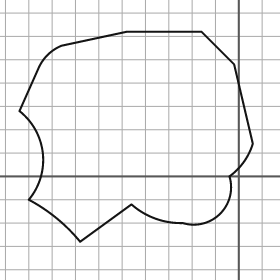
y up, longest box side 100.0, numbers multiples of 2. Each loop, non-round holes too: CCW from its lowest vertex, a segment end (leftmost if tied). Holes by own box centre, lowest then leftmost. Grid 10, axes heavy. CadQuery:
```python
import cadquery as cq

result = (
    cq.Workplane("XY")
    .moveTo(-68.0, -28.0)
    .lineTo(-46.0, -12.0)
    .threePointArc((-36.0, -18.0), (-24.0, -20.0))
    .threePointArc((-8.0, -16.0), (-4.0, 0.0))
    .threePointArc((2.0, 6.0), (6.0, 14.0))
    .lineTo(-2.0, 48.0)
    .lineTo(-16.0, 62.0)
    .lineTo(-48.0, 62.0)
    .lineTo(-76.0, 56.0)
    .threePointArc((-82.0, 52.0), (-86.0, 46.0))
    .lineTo(-94.0, 28.0)
    .threePointArc((-84.0, 10.0), (-90.0, -10.0))
    .threePointArc((-78.0, -18.0), (-68.0, -28.0))
    .close()
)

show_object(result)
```